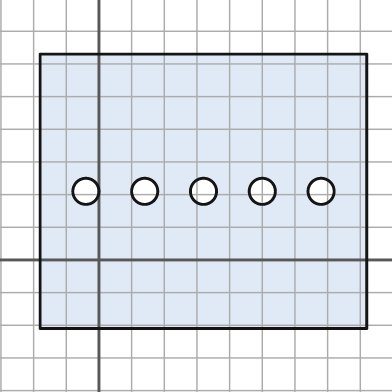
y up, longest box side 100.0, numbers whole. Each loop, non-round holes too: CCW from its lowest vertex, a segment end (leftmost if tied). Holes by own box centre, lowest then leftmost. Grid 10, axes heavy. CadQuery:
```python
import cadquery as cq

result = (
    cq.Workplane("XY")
    .moveTo(-18.0, -21.0)
    .lineTo(82.0, -21.0)
    .lineTo(82.0, 63.0)
    .lineTo(-18.0, 63.0)
    .close()
    .moveTo(-4.0, 21.0)
    .circle(4.0)
    .moveTo(14.0, 21.0)
    .circle(4.0)
    .moveTo(32.0, 21.0)
    .circle(4.0)
    .moveTo(50.0, 21.0)
    .circle(4.0)
    .moveTo(68.0, 21.0)
    .circle(4.0)
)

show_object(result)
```